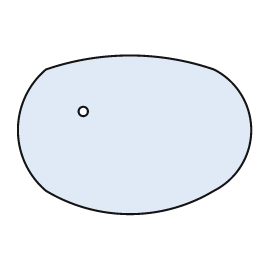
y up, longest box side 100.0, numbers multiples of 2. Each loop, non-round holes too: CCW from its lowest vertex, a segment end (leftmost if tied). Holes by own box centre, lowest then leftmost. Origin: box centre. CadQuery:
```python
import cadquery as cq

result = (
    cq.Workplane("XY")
    .moveTo(-38.0, -24.0)
    .threePointArc((-2.0, -34.0), (34.0, -24.0))
    .threePointArc((50.0, 2.0), (34.0, 28.0))
    .threePointArc((-2.0, 34.0), (-38.0, 28.0))
    .threePointArc((-50.0, 2.0), (-38.0, -24.0))
    .close()
    .moveTo(-22.0, 10.0)
    .circle(2.0)
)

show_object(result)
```